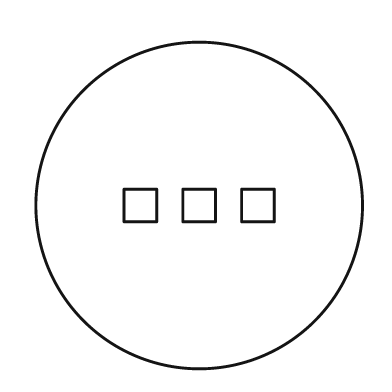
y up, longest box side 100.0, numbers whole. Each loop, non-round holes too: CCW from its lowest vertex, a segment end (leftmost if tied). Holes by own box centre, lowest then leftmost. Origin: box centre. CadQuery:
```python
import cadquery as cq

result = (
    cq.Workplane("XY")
    .moveTo(0.0, 0.0)
    .circle(50.0)
    .moveTo(-23.0, -5.0)
    .lineTo(-13.0, -5.0)
    .lineTo(-13.0, 5.0)
    .lineTo(-23.0, 5.0)
    .close()
    .moveTo(-5.0, -5.0)
    .lineTo(5.0, -5.0)
    .lineTo(5.0, 5.0)
    .lineTo(-5.0, 5.0)
    .close()
    .moveTo(13.0, -5.0)
    .lineTo(23.0, -5.0)
    .lineTo(23.0, 5.0)
    .lineTo(13.0, 5.0)
    .close()
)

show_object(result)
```